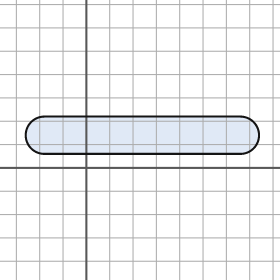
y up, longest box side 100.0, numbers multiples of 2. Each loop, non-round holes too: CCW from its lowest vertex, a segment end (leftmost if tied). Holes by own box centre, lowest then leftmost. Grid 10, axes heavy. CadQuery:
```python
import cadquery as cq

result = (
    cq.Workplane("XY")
    .moveTo(-18.0, 6.0)
    .lineTo(66.0, 6.0)
    .threePointArc((74.0, 14.0), (66.0, 22.0))
    .lineTo(-18.0, 22.0)
    .threePointArc((-26.0, 14.0), (-18.0, 6.0))
    .close()
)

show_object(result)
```